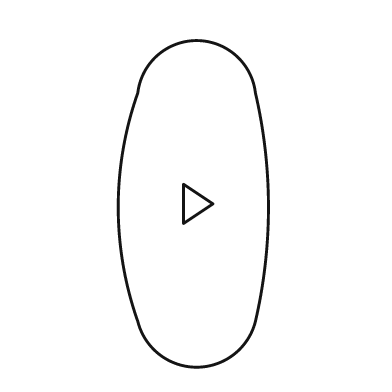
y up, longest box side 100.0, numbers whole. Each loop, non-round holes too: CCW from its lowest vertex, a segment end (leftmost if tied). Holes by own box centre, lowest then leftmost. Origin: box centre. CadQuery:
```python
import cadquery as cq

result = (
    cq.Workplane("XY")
    .moveTo(-17.0, -36.0)
    .threePointArc((1.0, -50.0), (19.0, -36.0))
    .threePointArc((23.0, -1.0), (19.0, 34.0))
    .threePointArc((1.0, 50.0), (-17.0, 34.0))
    .threePointArc((-23.0, -1.0), (-17.0, -36.0))
    .close()
    .moveTo(-3.0, -6.0)
    .lineTo(6.0, 0.0)
    .lineTo(-3.0, 6.0)
    .close()
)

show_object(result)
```